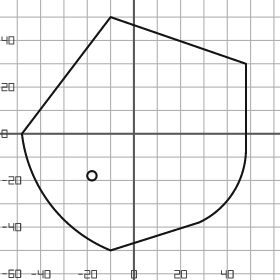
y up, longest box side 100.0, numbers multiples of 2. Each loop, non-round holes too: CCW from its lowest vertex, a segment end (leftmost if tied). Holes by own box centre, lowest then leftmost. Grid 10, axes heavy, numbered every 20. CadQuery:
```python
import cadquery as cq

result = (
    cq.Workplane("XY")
    .moveTo(-10.0, -50.0)
    .lineTo(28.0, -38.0)
    .threePointArc((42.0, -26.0), (48.0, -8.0))
    .lineTo(48.0, 30.0)
    .lineTo(-10.0, 50.0)
    .lineTo(-48.0, 0.0)
    .threePointArc((-36.0, -30.0), (-10.0, -50.0))
    .close()
    .moveTo(-18.0, -18.0)
    .circle(2.0)
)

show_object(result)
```